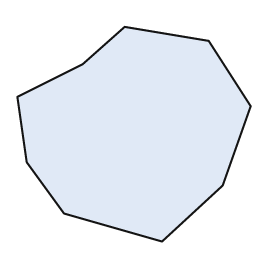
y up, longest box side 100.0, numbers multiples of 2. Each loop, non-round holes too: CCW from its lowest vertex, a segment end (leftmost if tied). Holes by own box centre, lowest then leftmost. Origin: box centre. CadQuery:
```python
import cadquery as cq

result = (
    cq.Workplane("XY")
    .moveTo(12.0, -46.0)
    .lineTo(38.0, -22.0)
    .lineTo(50.0, 12.0)
    .lineTo(32.0, 40.0)
    .lineTo(-4.0, 46.0)
    .lineTo(-22.0, 30.0)
    .lineTo(-50.0, 16.0)
    .lineTo(-46.0, -12.0)
    .lineTo(-30.0, -34.0)
    .close()
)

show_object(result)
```